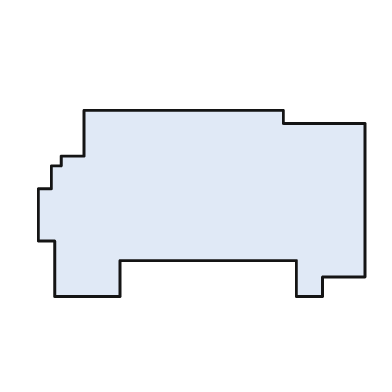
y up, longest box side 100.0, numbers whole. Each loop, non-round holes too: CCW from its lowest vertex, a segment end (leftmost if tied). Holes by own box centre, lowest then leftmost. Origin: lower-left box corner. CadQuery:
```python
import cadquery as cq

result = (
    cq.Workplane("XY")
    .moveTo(5.0, 0.0)
    .lineTo(25.0, 0.0)
    .lineTo(25.0, 11.0)
    .lineTo(79.0, 11.0)
    .lineTo(79.0, 0.0)
    .lineTo(87.0, 0.0)
    .lineTo(87.0, 6.0)
    .lineTo(100.0, 6.0)
    .lineTo(100.0, 53.0)
    .lineTo(75.0, 53.0)
    .lineTo(75.0, 57.0)
    .lineTo(14.0, 57.0)
    .lineTo(14.0, 43.0)
    .lineTo(7.0, 43.0)
    .lineTo(7.0, 40.0)
    .lineTo(4.0, 40.0)
    .lineTo(4.0, 33.0)
    .lineTo(0.0, 33.0)
    .lineTo(0.0, 17.0)
    .lineTo(5.0, 17.0)
    .close()
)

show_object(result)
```